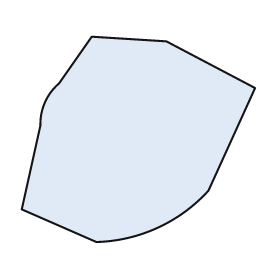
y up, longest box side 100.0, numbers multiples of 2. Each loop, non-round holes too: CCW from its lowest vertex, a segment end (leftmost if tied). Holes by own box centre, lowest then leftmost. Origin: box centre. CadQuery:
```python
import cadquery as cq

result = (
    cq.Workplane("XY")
    .moveTo(-18.0, -44.0)
    .threePointArc((8.0, -38.0), (30.0, -22.0))
    .lineTo(50.0, 22.0)
    .lineTo(12.0, 42.0)
    .lineTo(-20.0, 44.0)
    .lineTo(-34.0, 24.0)
    .threePointArc((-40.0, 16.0), (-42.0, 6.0))
    .lineTo(-50.0, -30.0)
    .close()
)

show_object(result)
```